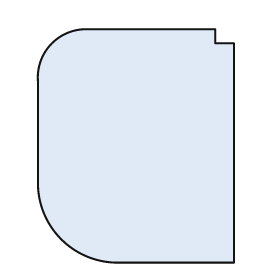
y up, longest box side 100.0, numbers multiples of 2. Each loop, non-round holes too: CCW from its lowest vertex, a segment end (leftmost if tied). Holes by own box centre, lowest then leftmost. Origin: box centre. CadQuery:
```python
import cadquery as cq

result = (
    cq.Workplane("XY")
    .moveTo(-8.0, -50.0)
    .lineTo(42.0, -50.0)
    .lineTo(42.0, 44.0)
    .lineTo(34.0, 44.0)
    .lineTo(34.0, 50.0)
    .lineTo(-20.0, 50.0)
    .threePointArc((-36.0, 44.0), (-42.0, 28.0))
    .lineTo(-42.0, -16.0)
    .threePointArc((-32.0, -40.0), (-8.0, -50.0))
    .close()
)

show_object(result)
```